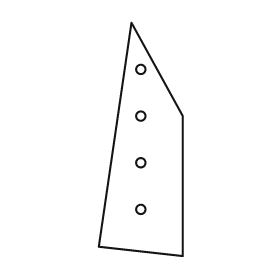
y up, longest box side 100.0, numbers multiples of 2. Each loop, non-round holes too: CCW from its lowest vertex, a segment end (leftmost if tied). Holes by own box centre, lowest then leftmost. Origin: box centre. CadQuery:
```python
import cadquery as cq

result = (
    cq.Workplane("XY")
    .moveTo(18.0, -50.0)
    .lineTo(18.0, 10.0)
    .lineTo(-4.0, 50.0)
    .lineTo(-18.0, -46.0)
    .close()
    .moveTo(0.0, -30.0)
    .circle(2.0)
    .moveTo(0.0, -10.0)
    .circle(2.0)
    .moveTo(0.0, 10.0)
    .circle(2.0)
    .moveTo(0.0, 30.0)
    .circle(2.0)
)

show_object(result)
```